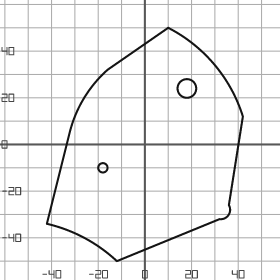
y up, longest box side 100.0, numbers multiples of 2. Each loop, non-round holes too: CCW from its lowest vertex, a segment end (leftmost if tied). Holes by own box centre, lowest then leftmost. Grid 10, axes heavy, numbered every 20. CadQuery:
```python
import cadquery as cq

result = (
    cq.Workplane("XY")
    .moveTo(-12.0, -50.0)
    .lineTo(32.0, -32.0)
    .threePointArc((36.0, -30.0), (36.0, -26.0))
    .lineTo(42.0, 12.0)
    .threePointArc((30.0, 34.0), (10.0, 50.0))
    .lineTo(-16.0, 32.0)
    .threePointArc((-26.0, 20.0), (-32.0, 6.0))
    .lineTo(-42.0, -34.0)
    .threePointArc((-26.0, -40.0), (-12.0, -50.0))
    .close()
    .moveTo(-18.0, -10.0)
    .circle(2.0)
    .moveTo(18.0, 24.0)
    .circle(4.0)
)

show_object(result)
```